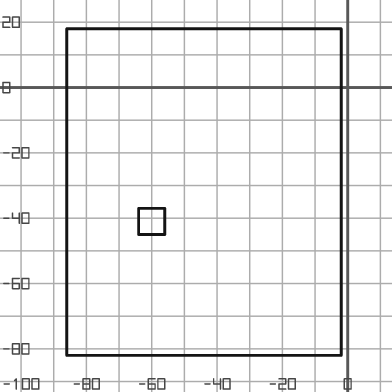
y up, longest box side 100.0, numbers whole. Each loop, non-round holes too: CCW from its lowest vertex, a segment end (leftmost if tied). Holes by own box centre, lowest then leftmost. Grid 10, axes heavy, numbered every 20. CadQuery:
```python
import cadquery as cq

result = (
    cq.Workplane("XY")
    .moveTo(-86.0, -82.0)
    .lineTo(-2.0, -82.0)
    .lineTo(-2.0, 18.0)
    .lineTo(-86.0, 18.0)
    .close()
    .moveTo(-64.0, -45.0)
    .lineTo(-56.0, -45.0)
    .lineTo(-56.0, -37.0)
    .lineTo(-64.0, -37.0)
    .close()
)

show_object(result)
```